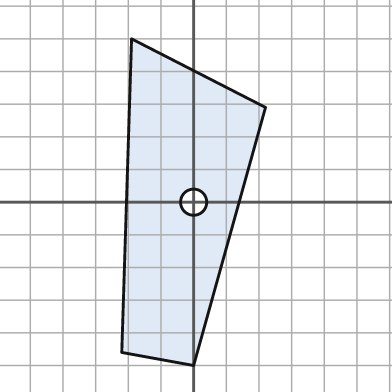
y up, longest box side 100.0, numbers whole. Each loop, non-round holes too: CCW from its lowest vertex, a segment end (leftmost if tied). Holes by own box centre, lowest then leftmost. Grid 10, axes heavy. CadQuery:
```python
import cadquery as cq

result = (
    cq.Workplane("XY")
    .moveTo(0.0, -50.0)
    .lineTo(22.0, 29.0)
    .lineTo(-19.0, 50.0)
    .lineTo(-22.0, -46.0)
    .close()
    .moveTo(0.0, 0.0)
    .circle(4.0)
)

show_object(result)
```